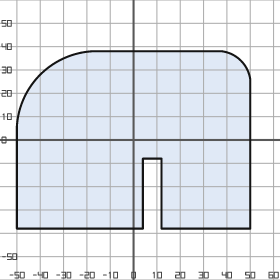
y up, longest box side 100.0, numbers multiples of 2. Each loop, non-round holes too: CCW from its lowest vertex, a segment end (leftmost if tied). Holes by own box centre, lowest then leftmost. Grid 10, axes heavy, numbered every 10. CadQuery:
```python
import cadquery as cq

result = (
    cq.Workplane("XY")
    .moveTo(-50.0, -38.0)
    .lineTo(4.0, -38.0)
    .lineTo(4.0, -8.0)
    .lineTo(12.0, -8.0)
    .lineTo(12.0, -38.0)
    .lineTo(50.0, -38.0)
    .lineTo(50.0, 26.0)
    .threePointArc((46.0, 34.0), (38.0, 38.0))
    .lineTo(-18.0, 38.0)
    .threePointArc((-40.0, 28.0), (-50.0, 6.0))
    .close()
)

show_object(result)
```